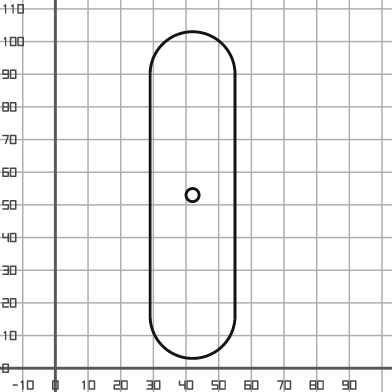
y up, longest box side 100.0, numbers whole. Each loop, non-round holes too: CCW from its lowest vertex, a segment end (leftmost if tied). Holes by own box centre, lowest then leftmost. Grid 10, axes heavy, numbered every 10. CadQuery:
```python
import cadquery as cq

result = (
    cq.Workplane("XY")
    .moveTo(29.0, 16.0)
    .threePointArc((42.0, 3.0), (55.0, 16.0))
    .lineTo(55.0, 90.0)
    .threePointArc((42.0, 103.0), (29.0, 90.0))
    .close()
    .moveTo(42.0, 53.0)
    .circle(2.0)
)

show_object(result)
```